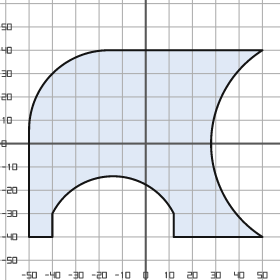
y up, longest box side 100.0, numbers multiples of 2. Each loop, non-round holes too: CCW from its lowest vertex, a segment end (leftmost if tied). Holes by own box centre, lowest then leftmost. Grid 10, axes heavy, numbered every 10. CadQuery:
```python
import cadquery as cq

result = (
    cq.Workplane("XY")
    .moveTo(-50.0, -40.0)
    .lineTo(-40.0, -40.0)
    .lineTo(-40.0, -30.0)
    .threePointArc((-14.0, -14.0), (12.0, -30.0))
    .lineTo(12.0, -40.0)
    .lineTo(50.0, -40.0)
    .threePointArc((28.0, 0.0), (50.0, 40.0))
    .lineTo(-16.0, 40.0)
    .threePointArc((-40.0, 30.0), (-50.0, 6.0))
    .close()
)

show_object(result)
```